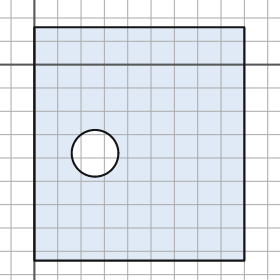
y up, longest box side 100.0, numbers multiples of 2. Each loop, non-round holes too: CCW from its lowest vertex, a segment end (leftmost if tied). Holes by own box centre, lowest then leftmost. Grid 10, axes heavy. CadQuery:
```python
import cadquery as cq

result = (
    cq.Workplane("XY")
    .moveTo(0.0, -84.0)
    .lineTo(90.0, -84.0)
    .lineTo(90.0, 16.0)
    .lineTo(0.0, 16.0)
    .close()
    .moveTo(26.0, -38.0)
    .circle(10.0)
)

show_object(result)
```